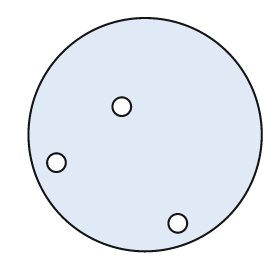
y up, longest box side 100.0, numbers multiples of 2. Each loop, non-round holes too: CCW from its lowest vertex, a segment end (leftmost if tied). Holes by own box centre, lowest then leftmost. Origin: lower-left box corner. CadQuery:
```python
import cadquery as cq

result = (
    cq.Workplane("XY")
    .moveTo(50.0, 50.0)
    .circle(50.0)
    .moveTo(64.0, 12.0)
    .circle(4.0)
    .moveTo(12.0, 38.0)
    .circle(4.0)
    .moveTo(40.0, 62.0)
    .circle(4.0)
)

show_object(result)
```